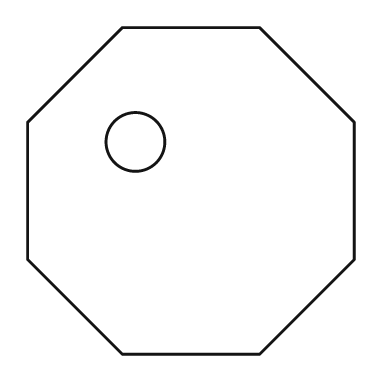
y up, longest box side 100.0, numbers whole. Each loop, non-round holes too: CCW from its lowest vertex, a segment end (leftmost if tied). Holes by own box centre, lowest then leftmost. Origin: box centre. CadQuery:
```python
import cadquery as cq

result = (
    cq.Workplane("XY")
    .moveTo(-21.0, -50.0)
    .lineTo(21.0, -50.0)
    .lineTo(50.0, -21.0)
    .lineTo(50.0, 21.0)
    .lineTo(21.0, 50.0)
    .lineTo(-21.0, 50.0)
    .lineTo(-50.0, 21.0)
    .lineTo(-50.0, -21.0)
    .close()
    .moveTo(-17.0, 15.0)
    .circle(9.0)
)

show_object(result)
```